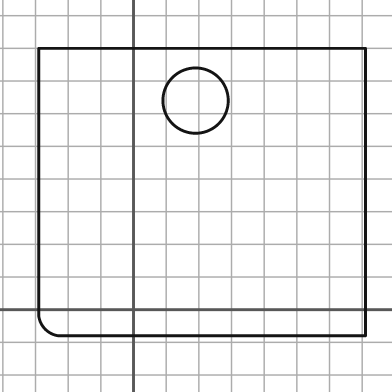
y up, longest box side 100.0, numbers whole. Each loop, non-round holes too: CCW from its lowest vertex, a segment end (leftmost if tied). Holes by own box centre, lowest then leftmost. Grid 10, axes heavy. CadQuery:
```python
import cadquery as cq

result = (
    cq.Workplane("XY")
    .moveTo(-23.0, -8.0)
    .lineTo(71.0, -8.0)
    .lineTo(71.0, 80.0)
    .lineTo(-29.0, 80.0)
    .lineTo(-29.0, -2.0)
    .threePointArc((-27.0, -6.0), (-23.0, -8.0))
    .close()
    .moveTo(19.0, 64.0)
    .circle(10.0)
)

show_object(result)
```